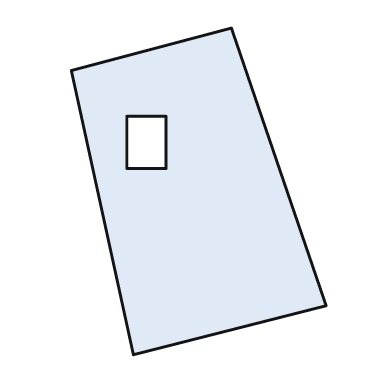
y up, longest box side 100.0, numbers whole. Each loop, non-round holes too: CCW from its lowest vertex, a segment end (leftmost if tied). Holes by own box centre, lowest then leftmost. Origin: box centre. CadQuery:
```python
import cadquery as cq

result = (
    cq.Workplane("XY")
    .moveTo(-20.0, -50.0)
    .lineTo(39.0, -35.0)
    .lineTo(10.0, 50.0)
    .lineTo(-39.0, 37.0)
    .close()
    .moveTo(-22.0, 7.0)
    .lineTo(-10.0, 7.0)
    .lineTo(-10.0, 23.0)
    .lineTo(-22.0, 23.0)
    .close()
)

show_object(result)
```